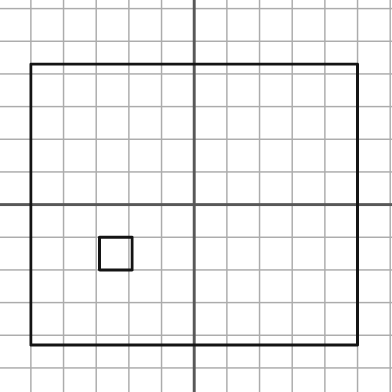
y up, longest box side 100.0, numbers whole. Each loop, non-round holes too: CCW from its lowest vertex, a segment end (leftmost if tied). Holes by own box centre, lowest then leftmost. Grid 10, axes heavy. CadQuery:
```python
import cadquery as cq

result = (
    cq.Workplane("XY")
    .moveTo(-50.0, -43.0)
    .lineTo(50.0, -43.0)
    .lineTo(50.0, 43.0)
    .lineTo(-50.0, 43.0)
    .close()
    .moveTo(-29.0, -20.0)
    .lineTo(-19.0, -20.0)
    .lineTo(-19.0, -10.0)
    .lineTo(-29.0, -10.0)
    .close()
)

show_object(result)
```